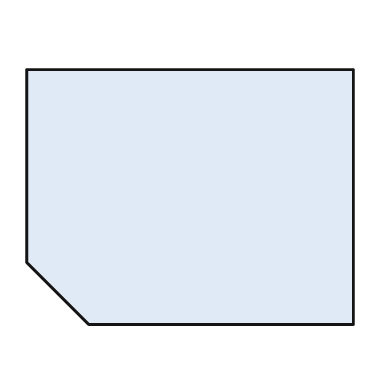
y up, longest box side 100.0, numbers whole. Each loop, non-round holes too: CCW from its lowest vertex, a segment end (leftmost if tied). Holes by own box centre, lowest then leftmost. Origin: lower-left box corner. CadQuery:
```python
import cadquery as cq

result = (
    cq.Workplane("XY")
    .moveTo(19.0, 0.0)
    .lineTo(100.0, 0.0)
    .lineTo(100.0, 78.0)
    .lineTo(0.0, 78.0)
    .lineTo(0.0, 19.0)
    .close()
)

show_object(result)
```